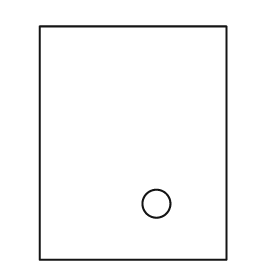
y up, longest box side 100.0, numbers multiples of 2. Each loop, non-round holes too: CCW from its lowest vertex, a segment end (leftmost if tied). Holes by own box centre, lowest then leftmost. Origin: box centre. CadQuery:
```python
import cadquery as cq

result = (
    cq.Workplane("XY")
    .moveTo(-40.0, -50.0)
    .lineTo(40.0, -50.0)
    .lineTo(40.0, 50.0)
    .lineTo(-40.0, 50.0)
    .close()
    .moveTo(10.0, -26.0)
    .circle(6.0)
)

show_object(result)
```